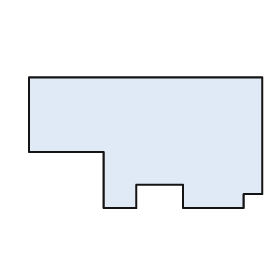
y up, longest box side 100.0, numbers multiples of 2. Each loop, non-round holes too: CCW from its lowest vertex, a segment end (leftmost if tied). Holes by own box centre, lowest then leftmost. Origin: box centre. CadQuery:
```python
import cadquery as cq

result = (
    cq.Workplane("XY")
    .moveTo(-18.0, -28.0)
    .lineTo(-4.0, -28.0)
    .lineTo(-4.0, -18.0)
    .lineTo(16.0, -18.0)
    .lineTo(16.0, -28.0)
    .lineTo(42.0, -28.0)
    .lineTo(42.0, -22.0)
    .lineTo(50.0, -22.0)
    .lineTo(50.0, 28.0)
    .lineTo(-50.0, 28.0)
    .lineTo(-50.0, -4.0)
    .lineTo(-18.0, -4.0)
    .close()
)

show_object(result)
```